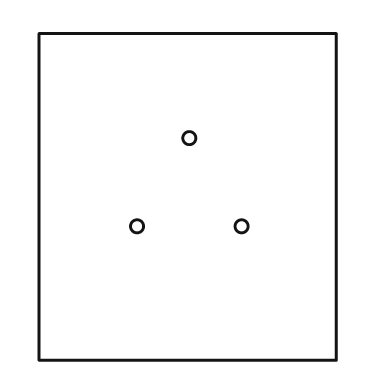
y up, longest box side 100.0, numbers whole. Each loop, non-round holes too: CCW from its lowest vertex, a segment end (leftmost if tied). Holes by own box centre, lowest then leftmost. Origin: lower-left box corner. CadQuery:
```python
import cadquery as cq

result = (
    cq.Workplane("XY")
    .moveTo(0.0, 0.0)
    .lineTo(91.0, 0.0)
    .lineTo(91.0, 100.0)
    .lineTo(0.0, 100.0)
    .close()
    .moveTo(30.0, 41.0)
    .circle(2.0)
    .moveTo(62.0, 41.0)
    .circle(2.0)
    .moveTo(46.0, 68.0)
    .circle(2.0)
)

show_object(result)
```